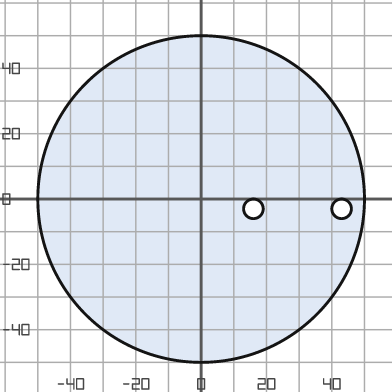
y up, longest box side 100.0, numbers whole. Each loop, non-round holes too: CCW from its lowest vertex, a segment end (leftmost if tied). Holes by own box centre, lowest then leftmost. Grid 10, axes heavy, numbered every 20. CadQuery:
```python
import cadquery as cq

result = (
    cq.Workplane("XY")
    .moveTo(0.0, 0.0)
    .circle(50.0)
    .moveTo(16.0, -3.0)
    .circle(3.0)
    .moveTo(43.0, -3.0)
    .circle(3.0)
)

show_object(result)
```